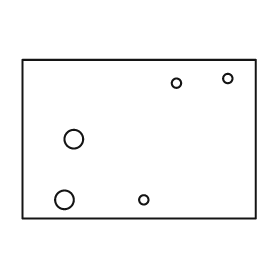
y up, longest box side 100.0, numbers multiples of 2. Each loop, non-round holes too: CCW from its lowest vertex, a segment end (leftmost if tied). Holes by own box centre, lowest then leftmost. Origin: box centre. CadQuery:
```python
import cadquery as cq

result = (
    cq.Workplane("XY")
    .moveTo(-50.0, -34.0)
    .lineTo(50.0, -34.0)
    .lineTo(50.0, 34.0)
    .lineTo(-50.0, 34.0)
    .close()
    .moveTo(-32.0, -26.0)
    .circle(4.0)
    .moveTo(2.0, -26.0)
    .circle(2.0)
    .moveTo(-28.0, 0.0)
    .circle(4.0)
    .moveTo(16.0, 24.0)
    .circle(2.0)
    .moveTo(38.0, 26.0)
    .circle(2.0)
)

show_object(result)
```